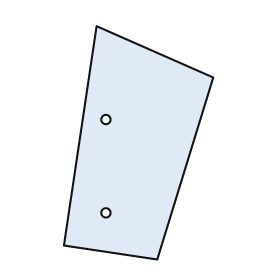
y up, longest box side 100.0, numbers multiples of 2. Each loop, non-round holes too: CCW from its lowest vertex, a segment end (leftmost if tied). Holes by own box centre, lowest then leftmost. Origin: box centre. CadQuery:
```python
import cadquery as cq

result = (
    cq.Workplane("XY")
    .moveTo(8.0, -50.0)
    .lineTo(32.0, 28.0)
    .lineTo(-18.0, 50.0)
    .lineTo(-32.0, -44.0)
    .close()
    .moveTo(-14.0, -30.0)
    .circle(2.0)
    .moveTo(-14.0, 10.0)
    .circle(2.0)
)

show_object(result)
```